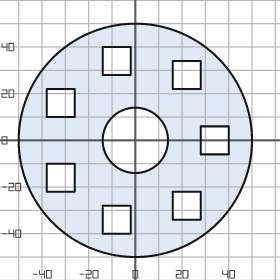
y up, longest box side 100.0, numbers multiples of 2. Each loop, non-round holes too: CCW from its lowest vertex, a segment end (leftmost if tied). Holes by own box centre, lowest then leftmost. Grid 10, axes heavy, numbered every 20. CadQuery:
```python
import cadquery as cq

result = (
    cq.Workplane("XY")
    .moveTo(0.0, 0.0)
    .circle(50.0)
    .moveTo(-14.0, -40.0)
    .lineTo(-2.0, -40.0)
    .lineTo(-2.0, -28.0)
    .lineTo(-14.0, -28.0)
    .close()
    .moveTo(16.0, -34.0)
    .lineTo(28.0, -34.0)
    .lineTo(28.0, -22.0)
    .lineTo(16.0, -22.0)
    .close()
    .moveTo(-38.0, -22.0)
    .lineTo(-26.0, -22.0)
    .lineTo(-26.0, -10.0)
    .lineTo(-38.0, -10.0)
    .close()
    .moveTo(0.0, 0.0)
    .circle(14.0)
    .moveTo(28.0, -6.0)
    .lineTo(40.0, -6.0)
    .lineTo(40.0, 6.0)
    .lineTo(28.0, 6.0)
    .close()
    .moveTo(-38.0, 10.0)
    .lineTo(-26.0, 10.0)
    .lineTo(-26.0, 22.0)
    .lineTo(-38.0, 22.0)
    .close()
    .moveTo(16.0, 22.0)
    .lineTo(28.0, 22.0)
    .lineTo(28.0, 34.0)
    .lineTo(16.0, 34.0)
    .close()
    .moveTo(-14.0, 28.0)
    .lineTo(-2.0, 28.0)
    .lineTo(-2.0, 40.0)
    .lineTo(-14.0, 40.0)
    .close()
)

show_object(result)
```